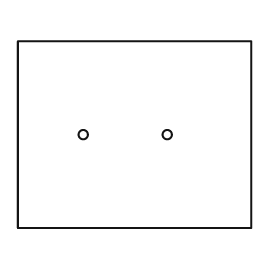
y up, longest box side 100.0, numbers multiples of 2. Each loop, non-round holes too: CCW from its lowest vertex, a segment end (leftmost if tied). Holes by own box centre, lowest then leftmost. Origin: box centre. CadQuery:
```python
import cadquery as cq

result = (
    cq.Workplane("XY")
    .moveTo(-50.0, -40.0)
    .lineTo(50.0, -40.0)
    .lineTo(50.0, 40.0)
    .lineTo(-50.0, 40.0)
    .close()
    .moveTo(-22.0, 0.0)
    .circle(2.0)
    .moveTo(14.0, 0.0)
    .circle(2.0)
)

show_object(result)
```